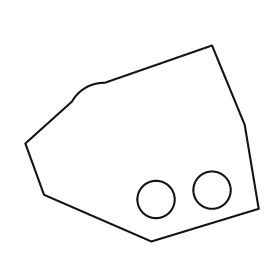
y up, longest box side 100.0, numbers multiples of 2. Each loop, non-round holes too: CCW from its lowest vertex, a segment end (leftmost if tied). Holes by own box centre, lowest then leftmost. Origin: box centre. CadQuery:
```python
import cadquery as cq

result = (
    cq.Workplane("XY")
    .moveTo(4.0, -42.0)
    .lineTo(50.0, -28.0)
    .lineTo(44.0, 8.0)
    .lineTo(30.0, 42.0)
    .lineTo(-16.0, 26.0)
    .threePointArc((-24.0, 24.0), (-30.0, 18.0))
    .lineTo(-50.0, 0.0)
    .lineTo(-42.0, -22.0)
    .close()
    .moveTo(6.0, -24.0)
    .circle(8.0)
    .moveTo(30.0, -20.0)
    .circle(8.0)
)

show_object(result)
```